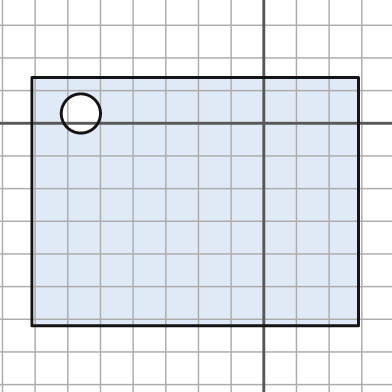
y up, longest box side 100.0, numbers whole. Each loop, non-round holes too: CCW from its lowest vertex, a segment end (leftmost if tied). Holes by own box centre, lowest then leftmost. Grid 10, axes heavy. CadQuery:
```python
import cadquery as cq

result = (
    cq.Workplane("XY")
    .moveTo(-71.0, -62.0)
    .lineTo(29.0, -62.0)
    .lineTo(29.0, 14.0)
    .lineTo(-71.0, 14.0)
    .close()
    .moveTo(-56.0, 3.0)
    .circle(6.0)
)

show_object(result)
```